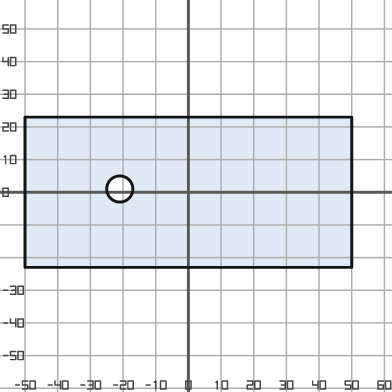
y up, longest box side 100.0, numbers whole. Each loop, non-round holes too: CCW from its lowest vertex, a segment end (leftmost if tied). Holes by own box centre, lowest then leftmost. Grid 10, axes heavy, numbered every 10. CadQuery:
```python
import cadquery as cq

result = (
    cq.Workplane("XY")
    .moveTo(-50.0, -23.0)
    .lineTo(50.0, -23.0)
    .lineTo(50.0, 23.0)
    .lineTo(-50.0, 23.0)
    .close()
    .moveTo(-21.0, 1.0)
    .circle(4.0)
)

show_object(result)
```